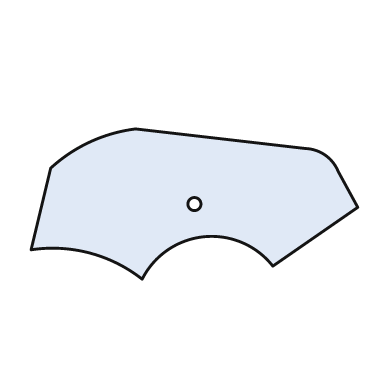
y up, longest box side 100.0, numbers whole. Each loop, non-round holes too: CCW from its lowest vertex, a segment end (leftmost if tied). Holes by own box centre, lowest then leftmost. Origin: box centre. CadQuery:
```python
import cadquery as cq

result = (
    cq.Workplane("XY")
    .moveTo(-16.0, -23.0)
    .threePointArc((3.0, -10.0), (24.0, -19.0))
    .lineTo(50.0, -1.0)
    .lineTo(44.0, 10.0)
    .threePointArc((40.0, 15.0), (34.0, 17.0))
    .lineTo(-18.0, 23.0)
    .threePointArc((-32.0, 19.0), (-44.0, 11.0))
    .lineTo(-50.0, -14.0)
    .threePointArc((-32.0, -15.0), (-16.0, -23.0))
    .close()
    .moveTo(0.0, 0.0)
    .circle(2.0)
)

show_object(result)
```